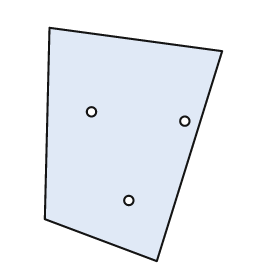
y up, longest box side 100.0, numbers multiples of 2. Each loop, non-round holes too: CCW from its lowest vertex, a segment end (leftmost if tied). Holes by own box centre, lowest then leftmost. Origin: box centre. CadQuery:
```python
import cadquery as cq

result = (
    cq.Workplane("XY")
    .moveTo(10.0, -50.0)
    .lineTo(38.0, 40.0)
    .lineTo(-36.0, 50.0)
    .lineTo(-38.0, -32.0)
    .close()
    .moveTo(-2.0, -24.0)
    .circle(2.0)
    .moveTo(22.0, 10.0)
    .circle(2.0)
    .moveTo(-18.0, 14.0)
    .circle(2.0)
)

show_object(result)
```